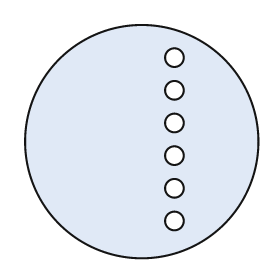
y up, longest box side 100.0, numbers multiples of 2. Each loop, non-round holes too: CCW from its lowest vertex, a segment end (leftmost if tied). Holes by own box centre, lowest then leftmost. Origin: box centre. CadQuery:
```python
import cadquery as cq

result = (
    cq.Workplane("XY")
    .moveTo(0.0, 0.0)
    .circle(50.0)
    .moveTo(14.0, -34.0)
    .circle(4.0)
    .moveTo(14.0, -20.0)
    .circle(4.0)
    .moveTo(14.0, -6.0)
    .circle(4.0)
    .moveTo(14.0, 8.0)
    .circle(4.0)
    .moveTo(14.0, 22.0)
    .circle(4.0)
    .moveTo(14.0, 36.0)
    .circle(4.0)
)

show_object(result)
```